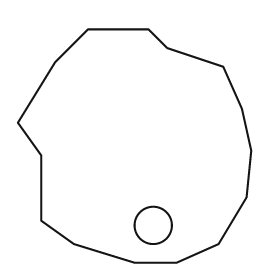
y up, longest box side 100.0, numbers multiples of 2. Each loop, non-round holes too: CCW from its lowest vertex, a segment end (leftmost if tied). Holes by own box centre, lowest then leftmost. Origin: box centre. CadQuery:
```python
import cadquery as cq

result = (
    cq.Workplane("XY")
    .moveTo(0.0, -50.0)
    .lineTo(18.0, -50.0)
    .lineTo(36.0, -42.0)
    .lineTo(48.0, -22.0)
    .lineTo(50.0, -2.0)
    .lineTo(46.0, 16.0)
    .lineTo(38.0, 34.0)
    .lineTo(14.0, 42.0)
    .lineTo(6.0, 50.0)
    .lineTo(-20.0, 50.0)
    .lineTo(-34.0, 36.0)
    .lineTo(-50.0, 10.0)
    .lineTo(-40.0, -4.0)
    .lineTo(-40.0, -32.0)
    .lineTo(-26.0, -42.0)
    .close()
    .moveTo(8.0, -34.0)
    .circle(8.0)
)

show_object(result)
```